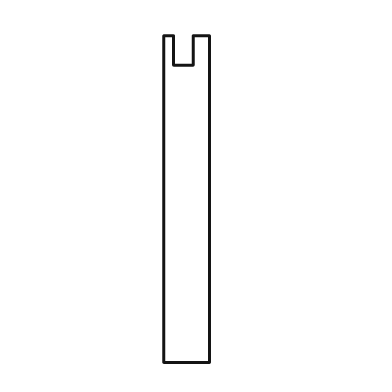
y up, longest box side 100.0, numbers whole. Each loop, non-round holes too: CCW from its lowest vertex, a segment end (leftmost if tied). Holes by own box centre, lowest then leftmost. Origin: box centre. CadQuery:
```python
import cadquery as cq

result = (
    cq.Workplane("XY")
    .moveTo(-7.0, -50.0)
    .lineTo(7.0, -50.0)
    .lineTo(7.0, 50.0)
    .lineTo(2.0, 50.0)
    .lineTo(2.0, 41.0)
    .lineTo(-4.0, 41.0)
    .lineTo(-4.0, 50.0)
    .lineTo(-7.0, 50.0)
    .close()
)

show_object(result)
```